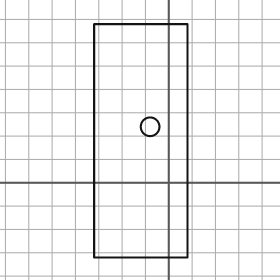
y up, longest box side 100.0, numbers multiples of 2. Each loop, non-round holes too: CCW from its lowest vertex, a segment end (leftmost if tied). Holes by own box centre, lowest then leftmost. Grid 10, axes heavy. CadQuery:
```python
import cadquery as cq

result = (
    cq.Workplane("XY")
    .moveTo(-32.0, -32.0)
    .lineTo(8.0, -32.0)
    .lineTo(8.0, 68.0)
    .lineTo(-32.0, 68.0)
    .close()
    .moveTo(-8.0, 24.0)
    .circle(4.0)
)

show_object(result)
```